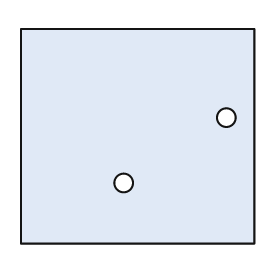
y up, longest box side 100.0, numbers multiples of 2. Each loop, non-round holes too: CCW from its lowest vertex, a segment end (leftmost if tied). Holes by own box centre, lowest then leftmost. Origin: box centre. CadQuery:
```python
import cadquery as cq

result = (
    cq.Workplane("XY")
    .moveTo(-50.0, -46.0)
    .lineTo(50.0, -46.0)
    .lineTo(50.0, 46.0)
    .lineTo(-50.0, 46.0)
    .close()
    .moveTo(-6.0, -20.0)
    .circle(4.0)
    .moveTo(38.0, 8.0)
    .circle(4.0)
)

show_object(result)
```